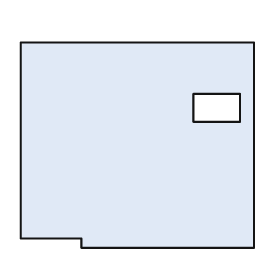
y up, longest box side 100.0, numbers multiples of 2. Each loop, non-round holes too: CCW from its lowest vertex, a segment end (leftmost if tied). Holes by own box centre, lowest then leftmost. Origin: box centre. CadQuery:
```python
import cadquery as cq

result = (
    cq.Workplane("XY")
    .moveTo(-24.0, -44.0)
    .lineTo(50.0, -44.0)
    .lineTo(50.0, 44.0)
    .lineTo(-50.0, 44.0)
    .lineTo(-50.0, -40.0)
    .lineTo(-24.0, -40.0)
    .close()
    .moveTo(24.0, 10.0)
    .lineTo(44.0, 10.0)
    .lineTo(44.0, 22.0)
    .lineTo(24.0, 22.0)
    .close()
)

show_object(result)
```